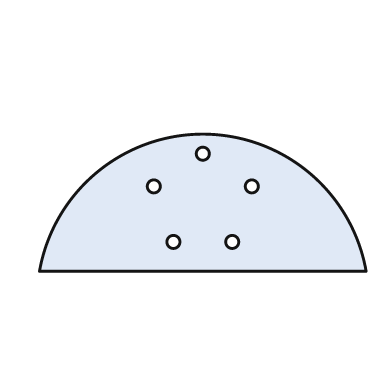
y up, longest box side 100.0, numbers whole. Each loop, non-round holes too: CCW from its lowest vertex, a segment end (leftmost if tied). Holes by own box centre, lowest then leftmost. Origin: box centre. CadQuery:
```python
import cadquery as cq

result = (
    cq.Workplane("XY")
    .moveTo(-50.0, -21.0)
    .lineTo(50.0, -21.0)
    .threePointArc((0.0, 21.0), (-50.0, -21.0))
    .close()
    .moveTo(-9.0, -12.0)
    .circle(2.0)
    .moveTo(9.0, -12.0)
    .circle(2.0)
    .moveTo(-15.0, 5.0)
    .circle(2.0)
    .moveTo(15.0, 5.0)
    .circle(2.0)
    .moveTo(0.0, 15.0)
    .circle(2.0)
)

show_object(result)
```